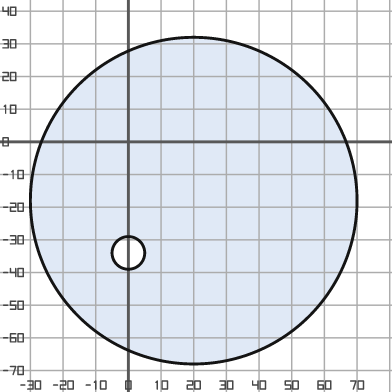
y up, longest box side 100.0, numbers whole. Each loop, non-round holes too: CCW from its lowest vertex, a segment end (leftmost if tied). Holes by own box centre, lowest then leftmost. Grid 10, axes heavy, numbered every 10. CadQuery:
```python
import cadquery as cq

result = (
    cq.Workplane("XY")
    .moveTo(20.0, -18.0)
    .circle(50.0)
    .moveTo(0.0, -34.0)
    .circle(5.0)
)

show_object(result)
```